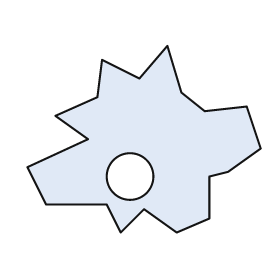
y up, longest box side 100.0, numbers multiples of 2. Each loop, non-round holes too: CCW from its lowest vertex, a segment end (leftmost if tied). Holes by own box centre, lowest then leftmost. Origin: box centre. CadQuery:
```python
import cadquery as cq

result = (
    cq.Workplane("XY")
    .moveTo(-10.0, -40.0)
    .lineTo(0.0, -30.0)
    .lineTo(14.0, -40.0)
    .lineTo(28.0, -34.0)
    .lineTo(28.0, -16.0)
    .lineTo(36.0, -14.0)
    .lineTo(50.0, -4.0)
    .lineTo(44.0, 14.0)
    .lineTo(26.0, 12.0)
    .lineTo(16.0, 20.0)
    .lineTo(10.0, 40.0)
    .lineTo(-2.0, 26.0)
    .lineTo(-18.0, 34.0)
    .lineTo(-20.0, 18.0)
    .lineTo(-38.0, 10.0)
    .lineTo(-24.0, 0.0)
    .lineTo(-50.0, -12.0)
    .lineTo(-42.0, -28.0)
    .lineTo(-16.0, -28.0)
    .close()
    .moveTo(-6.0, -16.0)
    .circle(10.0)
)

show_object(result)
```